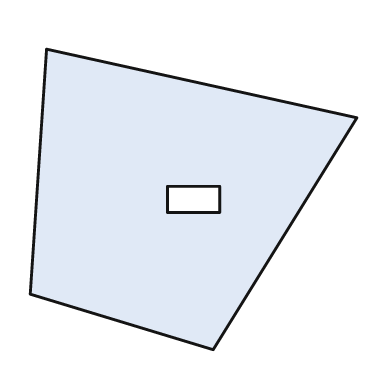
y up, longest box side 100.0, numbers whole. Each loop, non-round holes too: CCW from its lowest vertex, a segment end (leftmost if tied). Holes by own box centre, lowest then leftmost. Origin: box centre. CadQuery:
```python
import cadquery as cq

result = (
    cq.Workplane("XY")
    .moveTo(6.0, -46.0)
    .lineTo(50.0, 25.0)
    .lineTo(-45.0, 46.0)
    .lineTo(-50.0, -29.0)
    .close()
    .moveTo(-8.0, -4.0)
    .lineTo(8.0, -4.0)
    .lineTo(8.0, 4.0)
    .lineTo(-8.0, 4.0)
    .close()
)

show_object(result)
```